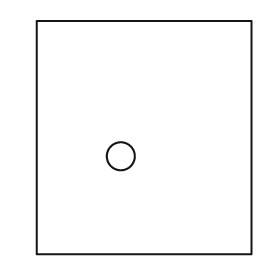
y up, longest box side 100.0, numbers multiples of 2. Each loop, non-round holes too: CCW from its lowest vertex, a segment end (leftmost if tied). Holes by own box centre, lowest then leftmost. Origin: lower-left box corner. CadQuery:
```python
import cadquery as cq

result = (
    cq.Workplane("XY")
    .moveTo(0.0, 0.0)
    .lineTo(92.0, 0.0)
    .lineTo(92.0, 100.0)
    .lineTo(0.0, 100.0)
    .close()
    .moveTo(36.0, 42.0)
    .circle(6.0)
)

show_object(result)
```